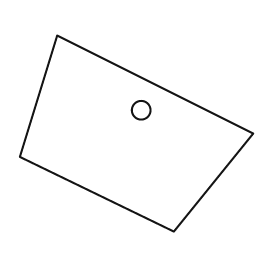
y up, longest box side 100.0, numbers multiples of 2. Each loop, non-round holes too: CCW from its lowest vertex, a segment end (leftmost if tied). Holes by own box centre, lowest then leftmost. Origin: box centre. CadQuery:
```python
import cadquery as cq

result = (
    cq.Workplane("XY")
    .moveTo(16.0, -42.0)
    .lineTo(50.0, 0.0)
    .lineTo(-34.0, 42.0)
    .lineTo(-50.0, -10.0)
    .close()
    .moveTo(2.0, 10.0)
    .circle(4.0)
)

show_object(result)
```